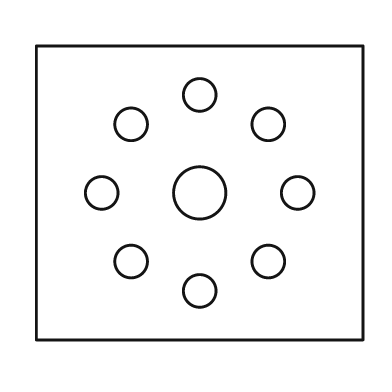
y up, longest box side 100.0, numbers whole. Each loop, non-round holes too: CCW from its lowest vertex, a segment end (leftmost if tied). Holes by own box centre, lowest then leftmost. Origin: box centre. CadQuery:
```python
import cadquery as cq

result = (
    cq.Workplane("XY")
    .moveTo(-50.0, -45.0)
    .lineTo(50.0, -45.0)
    .lineTo(50.0, 45.0)
    .lineTo(-50.0, 45.0)
    .close()
    .moveTo(0.0, -30.0)
    .circle(5.0)
    .moveTo(-21.0, -21.0)
    .circle(5.0)
    .moveTo(21.0, -21.0)
    .circle(5.0)
    .moveTo(-30.0, 0.0)
    .circle(5.0)
    .moveTo(0.0, 0.0)
    .circle(8.0)
    .moveTo(30.0, 0.0)
    .circle(5.0)
    .moveTo(-21.0, 21.0)
    .circle(5.0)
    .moveTo(21.0, 21.0)
    .circle(5.0)
    .moveTo(0.0, 30.0)
    .circle(5.0)
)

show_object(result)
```